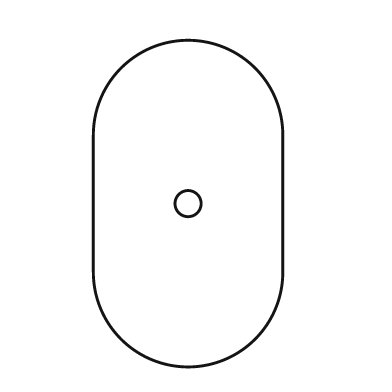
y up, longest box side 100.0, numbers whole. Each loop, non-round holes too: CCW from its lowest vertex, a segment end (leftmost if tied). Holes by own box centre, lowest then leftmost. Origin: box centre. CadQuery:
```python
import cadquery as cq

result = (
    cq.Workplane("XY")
    .moveTo(-29.0, -21.0)
    .threePointArc((0.0, -50.0), (29.0, -21.0))
    .lineTo(29.0, 21.0)
    .threePointArc((0.0, 50.0), (-29.0, 21.0))
    .close()
    .moveTo(0.0, 0.0)
    .circle(4.0)
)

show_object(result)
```